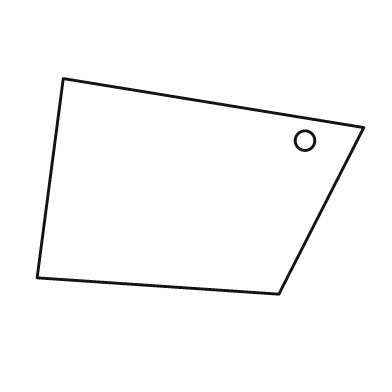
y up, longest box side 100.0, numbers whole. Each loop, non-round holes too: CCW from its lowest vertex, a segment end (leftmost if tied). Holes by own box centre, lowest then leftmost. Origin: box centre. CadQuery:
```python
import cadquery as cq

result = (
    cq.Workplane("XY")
    .moveTo(24.0, -33.0)
    .lineTo(50.0, 18.0)
    .lineTo(-42.0, 33.0)
    .lineTo(-50.0, -28.0)
    .close()
    .moveTo(32.0, 14.0)
    .circle(3.0)
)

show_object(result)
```